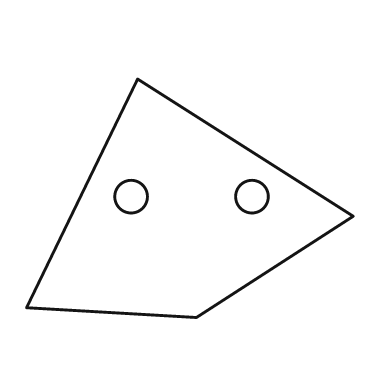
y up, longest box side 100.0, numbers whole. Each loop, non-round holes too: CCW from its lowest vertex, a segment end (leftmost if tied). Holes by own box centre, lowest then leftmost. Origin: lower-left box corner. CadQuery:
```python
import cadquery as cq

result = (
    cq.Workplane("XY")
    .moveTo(52.0, 0.0)
    .lineTo(100.0, 31.0)
    .lineTo(34.0, 73.0)
    .lineTo(0.0, 3.0)
    .close()
    .moveTo(32.0, 37.0)
    .circle(5.0)
    .moveTo(69.0, 37.0)
    .circle(5.0)
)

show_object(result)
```